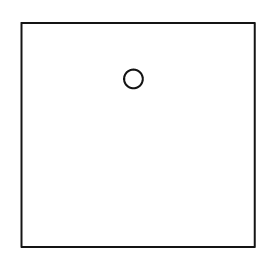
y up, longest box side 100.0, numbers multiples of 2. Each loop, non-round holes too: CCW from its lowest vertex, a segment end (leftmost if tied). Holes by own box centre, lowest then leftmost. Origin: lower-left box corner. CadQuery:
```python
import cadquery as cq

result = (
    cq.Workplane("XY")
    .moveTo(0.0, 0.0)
    .lineTo(100.0, 0.0)
    .lineTo(100.0, 96.0)
    .lineTo(0.0, 96.0)
    .close()
    .moveTo(48.0, 72.0)
    .circle(4.0)
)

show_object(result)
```